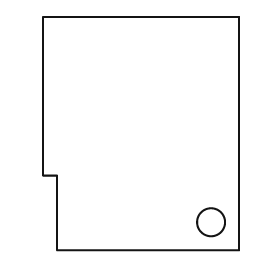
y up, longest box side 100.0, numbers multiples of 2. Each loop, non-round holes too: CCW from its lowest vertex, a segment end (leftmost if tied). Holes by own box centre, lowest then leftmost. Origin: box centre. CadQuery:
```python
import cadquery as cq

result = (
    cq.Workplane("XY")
    .moveTo(-36.0, -50.0)
    .lineTo(42.0, -50.0)
    .lineTo(42.0, 50.0)
    .lineTo(-42.0, 50.0)
    .lineTo(-42.0, -18.0)
    .lineTo(-36.0, -18.0)
    .close()
    .moveTo(30.0, -38.0)
    .circle(6.0)
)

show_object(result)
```